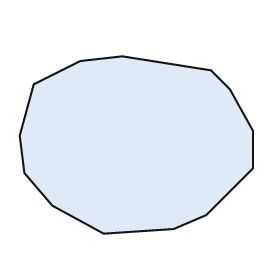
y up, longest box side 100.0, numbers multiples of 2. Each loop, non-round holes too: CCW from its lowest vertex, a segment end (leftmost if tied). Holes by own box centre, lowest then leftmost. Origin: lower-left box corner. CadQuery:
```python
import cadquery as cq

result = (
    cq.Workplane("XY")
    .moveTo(36.0, 0.0)
    .lineTo(66.0, 2.0)
    .lineTo(80.0, 8.0)
    .lineTo(100.0, 28.0)
    .lineTo(100.0, 44.0)
    .lineTo(90.0, 62.0)
    .lineTo(82.0, 70.0)
    .lineTo(44.0, 76.0)
    .lineTo(26.0, 74.0)
    .lineTo(6.0, 64.0)
    .lineTo(0.0, 42.0)
    .lineTo(2.0, 26.0)
    .lineTo(14.0, 12.0)
    .close()
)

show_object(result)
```